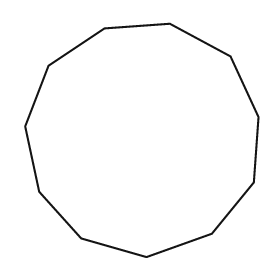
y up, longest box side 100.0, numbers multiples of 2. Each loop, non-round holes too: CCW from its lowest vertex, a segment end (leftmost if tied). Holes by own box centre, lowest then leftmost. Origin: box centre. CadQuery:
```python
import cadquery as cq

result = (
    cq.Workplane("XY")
    .moveTo(2.0, -50.0)
    .lineTo(30.0, -40.0)
    .lineTo(48.0, -18.0)
    .lineTo(50.0, 10.0)
    .lineTo(38.0, 36.0)
    .lineTo(12.0, 50.0)
    .lineTo(-16.0, 48.0)
    .lineTo(-40.0, 32.0)
    .lineTo(-50.0, 6.0)
    .lineTo(-44.0, -22.0)
    .lineTo(-26.0, -42.0)
    .close()
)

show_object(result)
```